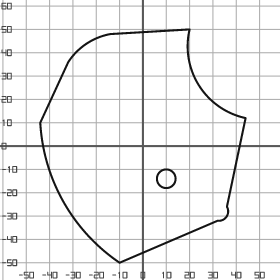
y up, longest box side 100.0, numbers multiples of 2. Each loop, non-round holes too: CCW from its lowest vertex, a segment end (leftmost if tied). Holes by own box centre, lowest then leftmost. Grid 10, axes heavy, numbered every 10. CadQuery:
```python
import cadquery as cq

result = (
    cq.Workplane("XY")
    .moveTo(-10.0, -50.0)
    .lineTo(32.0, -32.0)
    .threePointArc((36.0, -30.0), (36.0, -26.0))
    .lineTo(44.0, 12.0)
    .threePointArc((24.0, 26.0), (20.0, 50.0))
    .lineTo(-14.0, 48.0)
    .threePointArc((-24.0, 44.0), (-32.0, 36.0))
    .lineTo(-44.0, 10.0)
    .threePointArc((-34.0, -24.0), (-10.0, -50.0))
    .close()
    .moveTo(10.0, -14.0)
    .circle(4.0)
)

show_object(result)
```